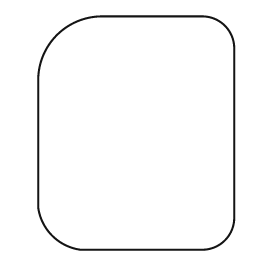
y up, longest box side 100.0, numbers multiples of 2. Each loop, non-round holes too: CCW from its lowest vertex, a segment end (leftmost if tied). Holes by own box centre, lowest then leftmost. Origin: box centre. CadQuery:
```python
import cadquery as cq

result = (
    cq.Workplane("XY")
    .moveTo(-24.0, -50.0)
    .lineTo(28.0, -50.0)
    .threePointArc((38.0, -46.0), (42.0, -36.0))
    .lineTo(42.0, 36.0)
    .threePointArc((38.0, 46.0), (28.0, 50.0))
    .lineTo(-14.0, 50.0)
    .threePointArc((-34.0, 42.0), (-42.0, 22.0))
    .lineTo(-42.0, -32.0)
    .threePointArc((-36.0, -44.0), (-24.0, -50.0))
    .close()
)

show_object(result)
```